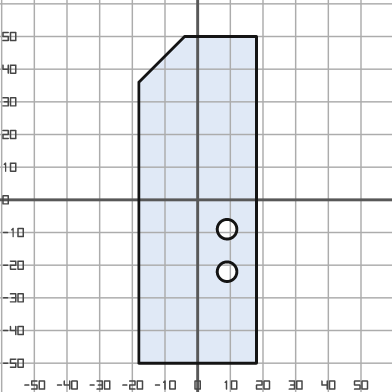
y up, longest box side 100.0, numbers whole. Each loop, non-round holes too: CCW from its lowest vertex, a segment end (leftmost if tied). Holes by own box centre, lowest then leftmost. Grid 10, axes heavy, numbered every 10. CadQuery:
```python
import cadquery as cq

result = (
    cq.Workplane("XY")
    .moveTo(-18.0, -50.0)
    .lineTo(18.0, -50.0)
    .lineTo(18.0, 50.0)
    .lineTo(-4.0, 50.0)
    .lineTo(-18.0, 36.0)
    .close()
    .moveTo(9.0, -22.0)
    .circle(3.0)
    .moveTo(9.0, -9.0)
    .circle(3.0)
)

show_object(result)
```